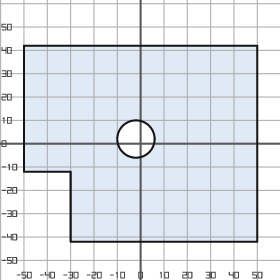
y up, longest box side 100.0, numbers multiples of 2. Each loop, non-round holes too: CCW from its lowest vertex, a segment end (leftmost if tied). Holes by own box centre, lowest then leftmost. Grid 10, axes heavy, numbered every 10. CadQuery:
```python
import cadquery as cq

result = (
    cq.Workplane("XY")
    .moveTo(-30.0, -42.0)
    .lineTo(50.0, -42.0)
    .lineTo(50.0, 42.0)
    .lineTo(-50.0, 42.0)
    .lineTo(-50.0, -12.0)
    .lineTo(-30.0, -12.0)
    .close()
    .moveTo(-2.0, 2.0)
    .circle(8.0)
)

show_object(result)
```